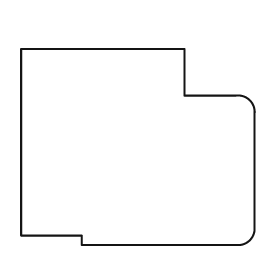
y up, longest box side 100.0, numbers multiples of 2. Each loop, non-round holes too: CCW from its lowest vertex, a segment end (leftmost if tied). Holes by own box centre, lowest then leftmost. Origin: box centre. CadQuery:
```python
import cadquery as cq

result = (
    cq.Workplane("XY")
    .moveTo(-24.0, -42.0)
    .lineTo(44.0, -42.0)
    .threePointArc((48.0, -40.0), (50.0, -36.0))
    .lineTo(50.0, 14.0)
    .threePointArc((48.0, 20.0), (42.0, 22.0))
    .lineTo(20.0, 22.0)
    .lineTo(20.0, 42.0)
    .lineTo(-50.0, 42.0)
    .lineTo(-50.0, -38.0)
    .lineTo(-24.0, -38.0)
    .close()
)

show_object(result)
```